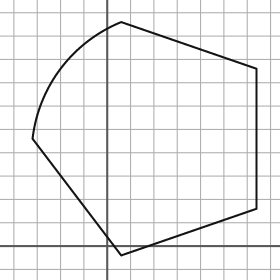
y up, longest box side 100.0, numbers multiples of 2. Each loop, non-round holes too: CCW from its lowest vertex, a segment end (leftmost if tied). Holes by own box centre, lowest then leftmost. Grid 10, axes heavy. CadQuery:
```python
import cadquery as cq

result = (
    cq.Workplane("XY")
    .moveTo(6.0, -4.0)
    .lineTo(64.0, 16.0)
    .lineTo(64.0, 76.0)
    .lineTo(6.0, 96.0)
    .threePointArc((-20.0, 76.0), (-32.0, 46.0))
    .close()
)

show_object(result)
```